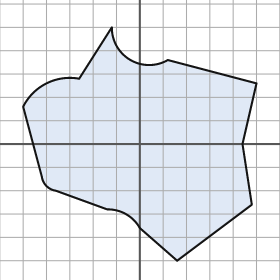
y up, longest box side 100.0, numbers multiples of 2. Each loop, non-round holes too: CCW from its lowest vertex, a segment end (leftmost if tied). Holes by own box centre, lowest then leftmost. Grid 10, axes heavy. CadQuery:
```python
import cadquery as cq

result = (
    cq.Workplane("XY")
    .moveTo(16.0, -50.0)
    .lineTo(48.0, -26.0)
    .lineTo(44.0, 0.0)
    .lineTo(50.0, 26.0)
    .lineTo(12.0, 36.0)
    .threePointArc((-4.0, 36.0), (-12.0, 50.0))
    .lineTo(-26.0, 28.0)
    .threePointArc((-40.0, 26.0), (-50.0, 16.0))
    .lineTo(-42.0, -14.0)
    .threePointArc((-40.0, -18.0), (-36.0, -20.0))
    .lineTo(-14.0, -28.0)
    .threePointArc((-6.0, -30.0), (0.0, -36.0))
    .close()
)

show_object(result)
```